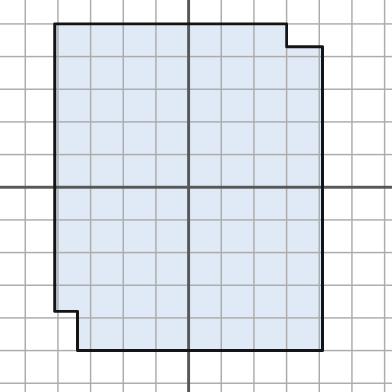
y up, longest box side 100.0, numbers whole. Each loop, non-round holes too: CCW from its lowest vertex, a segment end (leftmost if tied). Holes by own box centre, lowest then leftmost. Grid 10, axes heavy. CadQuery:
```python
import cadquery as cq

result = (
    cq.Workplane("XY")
    .moveTo(-34.0, -50.0)
    .lineTo(41.0, -50.0)
    .lineTo(41.0, 43.0)
    .lineTo(30.0, 43.0)
    .lineTo(30.0, 50.0)
    .lineTo(-41.0, 50.0)
    .lineTo(-41.0, -38.0)
    .lineTo(-34.0, -38.0)
    .close()
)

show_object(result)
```